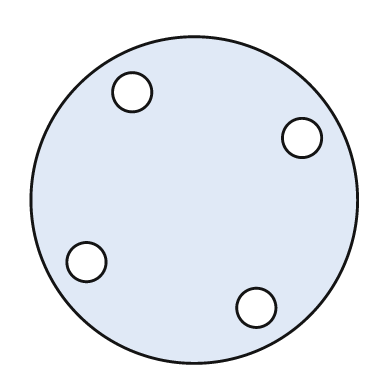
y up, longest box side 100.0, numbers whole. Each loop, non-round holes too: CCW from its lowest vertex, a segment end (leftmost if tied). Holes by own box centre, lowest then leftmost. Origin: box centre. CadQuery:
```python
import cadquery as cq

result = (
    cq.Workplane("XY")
    .moveTo(0.0, 0.0)
    .circle(50.0)
    .moveTo(19.0, -33.0)
    .circle(6.0)
    .moveTo(-33.0, -19.0)
    .circle(6.0)
    .moveTo(33.0, 19.0)
    .circle(6.0)
    .moveTo(-19.0, 33.0)
    .circle(6.0)
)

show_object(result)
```